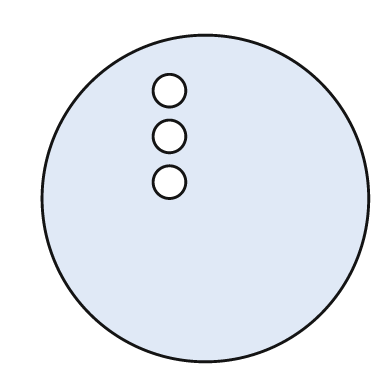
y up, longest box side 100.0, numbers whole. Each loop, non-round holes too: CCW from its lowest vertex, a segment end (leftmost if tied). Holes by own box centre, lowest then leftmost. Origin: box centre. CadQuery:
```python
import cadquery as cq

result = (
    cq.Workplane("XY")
    .moveTo(0.0, 0.0)
    .circle(50.0)
    .moveTo(-11.0, 5.0)
    .circle(5.0)
    .moveTo(-11.0, 19.0)
    .circle(5.0)
    .moveTo(-11.0, 33.0)
    .circle(5.0)
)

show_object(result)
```